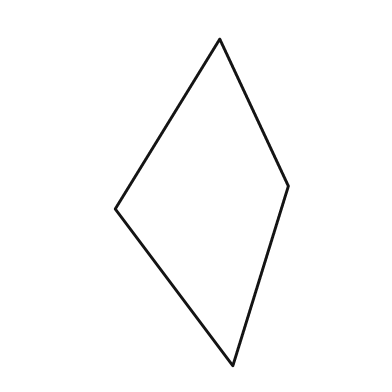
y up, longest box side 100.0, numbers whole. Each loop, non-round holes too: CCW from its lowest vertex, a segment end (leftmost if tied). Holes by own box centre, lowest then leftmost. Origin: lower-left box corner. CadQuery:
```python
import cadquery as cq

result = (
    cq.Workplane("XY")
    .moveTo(36.0, 0.0)
    .lineTo(53.0, 55.0)
    .lineTo(32.0, 100.0)
    .lineTo(0.0, 48.0)
    .close()
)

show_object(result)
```